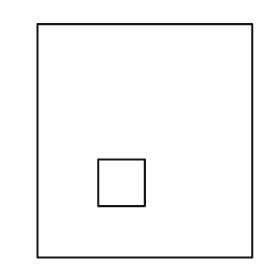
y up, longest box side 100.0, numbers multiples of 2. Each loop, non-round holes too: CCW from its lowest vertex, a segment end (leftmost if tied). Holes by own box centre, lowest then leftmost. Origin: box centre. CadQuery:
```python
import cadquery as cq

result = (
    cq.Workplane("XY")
    .moveTo(-46.0, -50.0)
    .lineTo(46.0, -50.0)
    .lineTo(46.0, 50.0)
    .lineTo(-46.0, 50.0)
    .close()
    .moveTo(-20.0, -28.0)
    .lineTo(0.0, -28.0)
    .lineTo(0.0, -8.0)
    .lineTo(-20.0, -8.0)
    .close()
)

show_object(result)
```